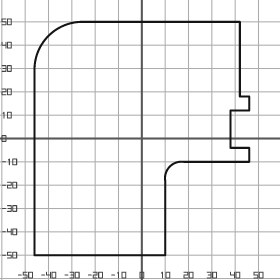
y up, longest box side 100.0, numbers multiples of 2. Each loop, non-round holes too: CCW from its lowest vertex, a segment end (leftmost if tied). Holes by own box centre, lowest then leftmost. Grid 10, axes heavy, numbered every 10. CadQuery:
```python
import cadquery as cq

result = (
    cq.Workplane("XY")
    .moveTo(-46.0, -50.0)
    .lineTo(10.0, -50.0)
    .lineTo(10.0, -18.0)
    .threePointArc((12.0, -12.0), (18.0, -10.0))
    .lineTo(46.0, -10.0)
    .lineTo(46.0, -4.0)
    .lineTo(38.0, -4.0)
    .lineTo(38.0, 12.0)
    .lineTo(46.0, 12.0)
    .lineTo(46.0, 18.0)
    .lineTo(42.0, 18.0)
    .lineTo(42.0, 50.0)
    .lineTo(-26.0, 50.0)
    .threePointArc((-40.0, 44.0), (-46.0, 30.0))
    .close()
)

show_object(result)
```